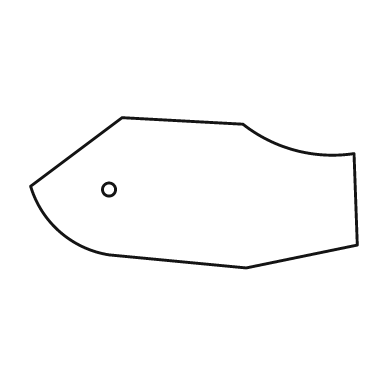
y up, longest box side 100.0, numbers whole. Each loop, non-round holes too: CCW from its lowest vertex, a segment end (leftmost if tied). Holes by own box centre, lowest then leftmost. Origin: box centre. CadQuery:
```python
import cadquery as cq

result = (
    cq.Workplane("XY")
    .moveTo(16.0, -23.0)
    .lineTo(50.0, -16.0)
    .lineTo(49.0, 12.0)
    .threePointArc((31.0, 13.0), (15.0, 21.0))
    .lineTo(-22.0, 23.0)
    .lineTo(-50.0, 2.0)
    .threePointArc((-41.0, -12.0), (-26.0, -19.0))
    .close()
    .moveTo(-26.0, 1.0)
    .circle(2.0)
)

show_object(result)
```